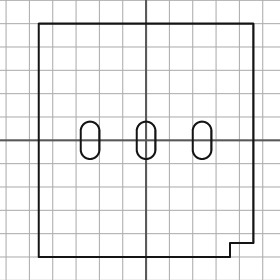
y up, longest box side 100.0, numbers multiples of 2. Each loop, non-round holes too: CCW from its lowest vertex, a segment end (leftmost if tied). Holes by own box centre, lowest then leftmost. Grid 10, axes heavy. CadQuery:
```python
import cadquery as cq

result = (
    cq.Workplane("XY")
    .moveTo(-46.0, -50.0)
    .lineTo(36.0, -50.0)
    .lineTo(36.0, -44.0)
    .lineTo(46.0, -44.0)
    .lineTo(46.0, 50.0)
    .lineTo(-46.0, 50.0)
    .close()
    .moveTo(-28.0, -4.0)
    .threePointArc((-24.0, -8.0), (-20.0, -4.0))
    .lineTo(-20.0, 4.0)
    .threePointArc((-24.0, 8.0), (-28.0, 4.0))
    .close()
    .moveTo(-4.0, -4.0)
    .threePointArc((0.0, -8.0), (4.0, -4.0))
    .lineTo(4.0, 4.0)
    .threePointArc((0.0, 8.0), (-4.0, 4.0))
    .close()
    .moveTo(20.0, -4.0)
    .threePointArc((24.0, -8.0), (28.0, -4.0))
    .lineTo(28.0, 4.0)
    .threePointArc((24.0, 8.0), (20.0, 4.0))
    .close()
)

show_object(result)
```